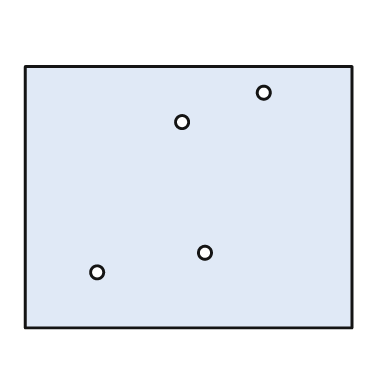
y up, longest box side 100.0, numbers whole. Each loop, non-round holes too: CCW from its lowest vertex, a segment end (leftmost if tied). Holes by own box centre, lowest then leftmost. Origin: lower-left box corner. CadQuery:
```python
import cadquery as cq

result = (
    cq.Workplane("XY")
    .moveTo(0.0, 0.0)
    .lineTo(100.0, 0.0)
    .lineTo(100.0, 80.0)
    .lineTo(0.0, 80.0)
    .close()
    .moveTo(22.0, 17.0)
    .circle(2.0)
    .moveTo(55.0, 23.0)
    .circle(2.0)
    .moveTo(48.0, 63.0)
    .circle(2.0)
    .moveTo(73.0, 72.0)
    .circle(2.0)
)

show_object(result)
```